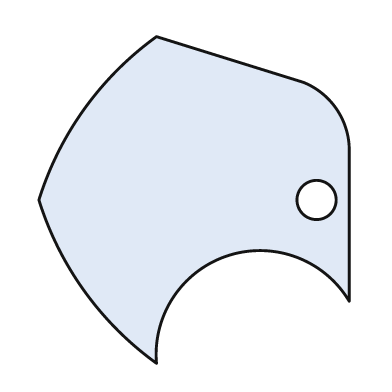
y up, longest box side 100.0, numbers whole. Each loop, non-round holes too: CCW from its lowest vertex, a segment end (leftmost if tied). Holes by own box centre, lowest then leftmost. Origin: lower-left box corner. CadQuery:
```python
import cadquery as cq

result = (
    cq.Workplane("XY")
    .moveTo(36.0, 0.0)
    .threePointArc((58.0, 33.0), (95.0, 19.0))
    .lineTo(95.0, 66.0)
    .threePointArc((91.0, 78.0), (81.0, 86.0))
    .lineTo(36.0, 100.0)
    .threePointArc((14.0, 78.0), (0.0, 50.0))
    .threePointArc((14.0, 22.0), (36.0, 0.0))
    .close()
    .moveTo(85.0, 50.0)
    .circle(6.0)
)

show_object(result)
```